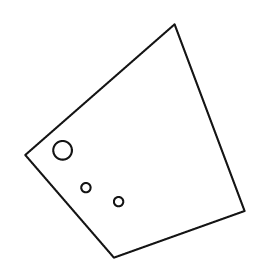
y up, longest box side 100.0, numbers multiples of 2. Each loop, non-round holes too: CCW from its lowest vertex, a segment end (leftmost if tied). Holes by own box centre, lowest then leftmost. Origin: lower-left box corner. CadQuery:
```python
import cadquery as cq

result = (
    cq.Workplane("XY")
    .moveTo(38.0, 0.0)
    .lineTo(94.0, 20.0)
    .lineTo(64.0, 100.0)
    .lineTo(0.0, 44.0)
    .close()
    .moveTo(40.0, 24.0)
    .circle(2.0)
    .moveTo(26.0, 30.0)
    .circle(2.0)
    .moveTo(16.0, 46.0)
    .circle(4.0)
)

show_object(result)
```